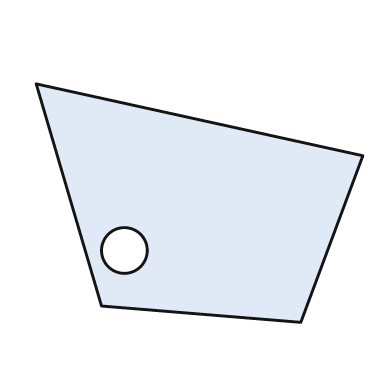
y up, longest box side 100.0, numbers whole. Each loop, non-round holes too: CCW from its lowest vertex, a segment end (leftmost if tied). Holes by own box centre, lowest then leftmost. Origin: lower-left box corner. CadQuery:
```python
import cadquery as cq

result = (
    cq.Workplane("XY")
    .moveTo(81.0, 0.0)
    .lineTo(100.0, 51.0)
    .lineTo(0.0, 73.0)
    .lineTo(20.0, 5.0)
    .close()
    .moveTo(27.0, 22.0)
    .circle(7.0)
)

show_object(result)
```